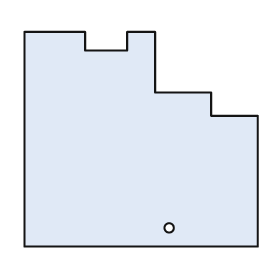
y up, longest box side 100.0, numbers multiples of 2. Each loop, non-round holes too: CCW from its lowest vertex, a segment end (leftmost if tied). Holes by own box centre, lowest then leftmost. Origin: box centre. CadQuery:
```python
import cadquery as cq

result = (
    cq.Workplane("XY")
    .moveTo(-50.0, -46.0)
    .lineTo(50.0, -46.0)
    .lineTo(50.0, 10.0)
    .lineTo(30.0, 10.0)
    .lineTo(30.0, 20.0)
    .lineTo(6.0, 20.0)
    .lineTo(6.0, 46.0)
    .lineTo(-6.0, 46.0)
    .lineTo(-6.0, 38.0)
    .lineTo(-24.0, 38.0)
    .lineTo(-24.0, 46.0)
    .lineTo(-50.0, 46.0)
    .close()
    .moveTo(12.0, -38.0)
    .circle(2.0)
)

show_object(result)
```